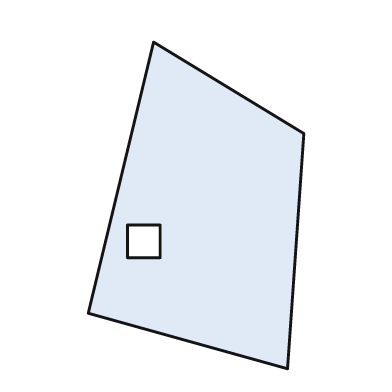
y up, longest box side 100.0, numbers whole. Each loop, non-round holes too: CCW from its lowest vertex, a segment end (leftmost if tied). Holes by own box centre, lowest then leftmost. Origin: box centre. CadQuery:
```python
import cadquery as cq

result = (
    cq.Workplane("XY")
    .moveTo(28.0, -50.0)
    .lineTo(33.0, 22.0)
    .lineTo(-13.0, 50.0)
    .lineTo(-33.0, -33.0)
    .close()
    .moveTo(-21.0, -16.0)
    .lineTo(-11.0, -16.0)
    .lineTo(-11.0, -6.0)
    .lineTo(-21.0, -6.0)
    .close()
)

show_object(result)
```